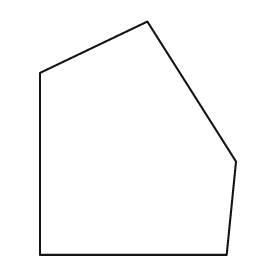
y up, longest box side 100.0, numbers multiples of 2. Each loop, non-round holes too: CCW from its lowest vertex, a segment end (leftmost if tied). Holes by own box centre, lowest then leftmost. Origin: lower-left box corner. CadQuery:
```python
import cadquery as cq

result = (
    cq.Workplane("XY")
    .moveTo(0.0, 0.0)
    .lineTo(80.0, 0.0)
    .lineTo(84.0, 40.0)
    .lineTo(46.0, 100.0)
    .lineTo(0.0, 78.0)
    .close()
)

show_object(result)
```